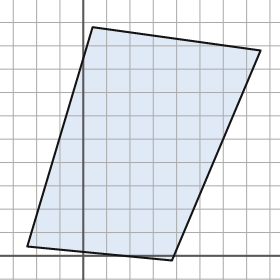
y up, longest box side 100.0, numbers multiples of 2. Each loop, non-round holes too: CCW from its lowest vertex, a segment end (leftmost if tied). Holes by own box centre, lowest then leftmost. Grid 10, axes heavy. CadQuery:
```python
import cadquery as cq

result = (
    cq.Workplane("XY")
    .moveTo(38.0, -2.0)
    .lineTo(76.0, 88.0)
    .lineTo(4.0, 98.0)
    .lineTo(-24.0, 4.0)
    .close()
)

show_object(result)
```